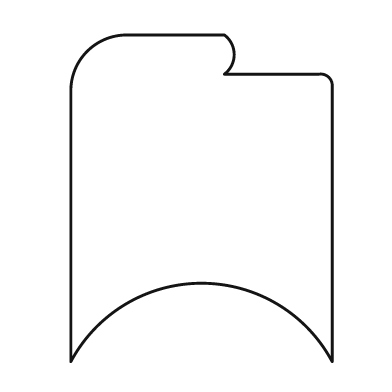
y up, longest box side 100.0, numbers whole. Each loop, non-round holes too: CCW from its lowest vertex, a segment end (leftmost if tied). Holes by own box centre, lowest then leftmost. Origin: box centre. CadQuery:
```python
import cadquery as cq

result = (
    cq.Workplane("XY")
    .moveTo(-40.0, -50.0)
    .threePointArc((0.0, -26.0), (40.0, -50.0))
    .lineTo(40.0, 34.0)
    .threePointArc((39.0, 37.0), (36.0, 38.0))
    .lineTo(7.0, 38.0)
    .threePointArc((10.0, 44.0), (7.0, 50.0))
    .lineTo(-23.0, 50.0)
    .threePointArc((-35.0, 45.0), (-40.0, 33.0))
    .close()
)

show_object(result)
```